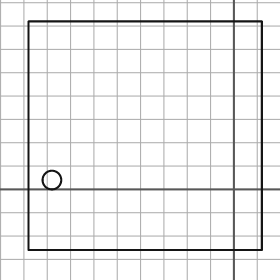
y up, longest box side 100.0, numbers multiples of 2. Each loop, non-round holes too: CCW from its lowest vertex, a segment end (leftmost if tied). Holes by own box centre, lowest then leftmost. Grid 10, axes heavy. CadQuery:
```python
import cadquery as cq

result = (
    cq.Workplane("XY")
    .moveTo(-88.0, -26.0)
    .lineTo(12.0, -26.0)
    .lineTo(12.0, 72.0)
    .lineTo(-88.0, 72.0)
    .close()
    .moveTo(-78.0, 4.0)
    .circle(4.0)
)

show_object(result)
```